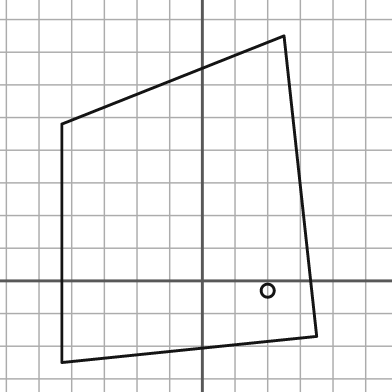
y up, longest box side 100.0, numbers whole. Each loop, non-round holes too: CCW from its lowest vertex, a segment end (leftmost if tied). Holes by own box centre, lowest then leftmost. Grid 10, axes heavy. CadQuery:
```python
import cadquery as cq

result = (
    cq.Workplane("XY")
    .moveTo(-43.0, -25.0)
    .lineTo(35.0, -17.0)
    .lineTo(25.0, 75.0)
    .lineTo(-43.0, 48.0)
    .close()
    .moveTo(20.0, -3.0)
    .circle(2.0)
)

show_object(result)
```